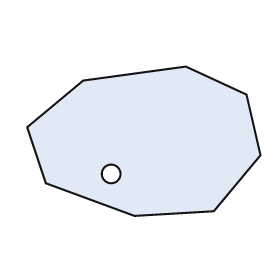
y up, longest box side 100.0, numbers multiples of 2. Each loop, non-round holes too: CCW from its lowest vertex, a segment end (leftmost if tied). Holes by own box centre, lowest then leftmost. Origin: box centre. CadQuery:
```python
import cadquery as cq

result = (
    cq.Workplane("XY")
    .moveTo(-4.0, -32.0)
    .lineTo(30.0, -30.0)
    .lineTo(50.0, -6.0)
    .lineTo(44.0, 20.0)
    .lineTo(18.0, 32.0)
    .lineTo(-26.0, 26.0)
    .lineTo(-50.0, 6.0)
    .lineTo(-42.0, -18.0)
    .close()
    .moveTo(-14.0, -14.0)
    .circle(4.0)
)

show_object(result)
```